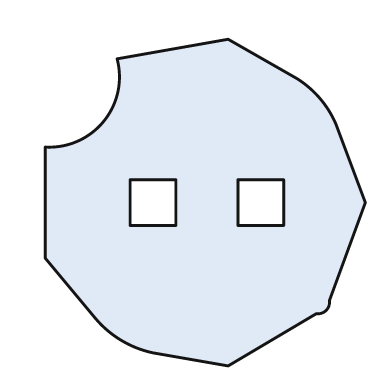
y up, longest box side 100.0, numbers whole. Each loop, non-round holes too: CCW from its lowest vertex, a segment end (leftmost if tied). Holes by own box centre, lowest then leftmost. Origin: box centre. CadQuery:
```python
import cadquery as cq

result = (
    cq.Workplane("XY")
    .moveTo(7.0, -50.0)
    .lineTo(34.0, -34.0)
    .threePointArc((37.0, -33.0), (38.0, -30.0))
    .lineTo(49.0, 0.0)
    .lineTo(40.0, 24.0)
    .threePointArc((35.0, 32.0), (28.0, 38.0))
    .lineTo(7.0, 50.0)
    .lineTo(-27.0, 44.0)
    .threePointArc((-31.0, 25.0), (-49.0, 17.0))
    .lineTo(-49.0, -17.0)
    .lineTo(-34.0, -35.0)
    .threePointArc((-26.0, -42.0), (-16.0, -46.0))
    .close()
    .moveTo(-23.0, -7.0)
    .lineTo(-9.0, -7.0)
    .lineTo(-9.0, 7.0)
    .lineTo(-23.0, 7.0)
    .close()
    .moveTo(10.0, -7.0)
    .lineTo(24.0, -7.0)
    .lineTo(24.0, 7.0)
    .lineTo(10.0, 7.0)
    .close()
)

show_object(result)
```